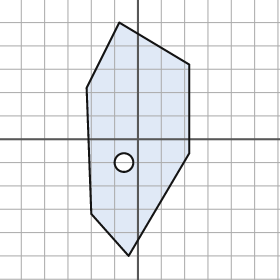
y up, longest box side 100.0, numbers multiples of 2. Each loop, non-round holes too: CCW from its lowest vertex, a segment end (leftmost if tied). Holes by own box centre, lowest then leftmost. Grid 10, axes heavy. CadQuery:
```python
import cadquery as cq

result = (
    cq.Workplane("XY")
    .moveTo(-4.0, -50.0)
    .lineTo(22.0, -6.0)
    .lineTo(22.0, 32.0)
    .lineTo(-8.0, 50.0)
    .lineTo(-22.0, 22.0)
    .lineTo(-20.0, -32.0)
    .close()
    .moveTo(-6.0, -10.0)
    .circle(4.0)
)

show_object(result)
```